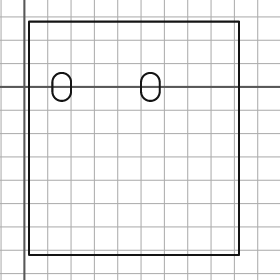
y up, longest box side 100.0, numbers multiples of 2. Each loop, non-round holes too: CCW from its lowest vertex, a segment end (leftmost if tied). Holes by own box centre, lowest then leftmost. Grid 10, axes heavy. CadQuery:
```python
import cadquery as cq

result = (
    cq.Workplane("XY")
    .moveTo(2.0, -72.0)
    .lineTo(92.0, -72.0)
    .lineTo(92.0, 28.0)
    .lineTo(2.0, 28.0)
    .close()
    .moveTo(12.0, -2.0)
    .threePointArc((16.0, -6.0), (20.0, -2.0))
    .lineTo(20.0, 2.0)
    .threePointArc((16.0, 6.0), (12.0, 2.0))
    .close()
    .moveTo(50.0, -2.0)
    .threePointArc((54.0, -6.0), (58.0, -2.0))
    .lineTo(58.0, 2.0)
    .threePointArc((54.0, 6.0), (50.0, 2.0))
    .close()
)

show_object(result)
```